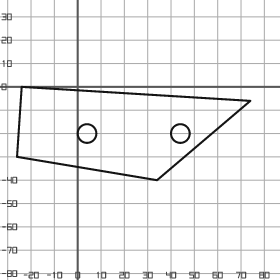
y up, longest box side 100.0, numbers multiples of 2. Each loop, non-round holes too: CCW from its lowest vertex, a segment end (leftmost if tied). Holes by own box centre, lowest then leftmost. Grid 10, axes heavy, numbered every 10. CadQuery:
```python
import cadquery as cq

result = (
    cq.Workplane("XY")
    .moveTo(34.0, -40.0)
    .lineTo(74.0, -6.0)
    .lineTo(-24.0, 0.0)
    .lineTo(-26.0, -30.0)
    .close()
    .moveTo(4.0, -20.0)
    .circle(4.0)
    .moveTo(44.0, -20.0)
    .circle(4.0)
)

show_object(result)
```